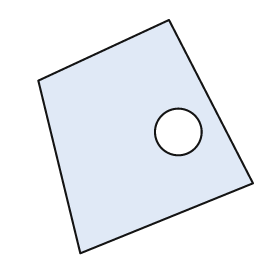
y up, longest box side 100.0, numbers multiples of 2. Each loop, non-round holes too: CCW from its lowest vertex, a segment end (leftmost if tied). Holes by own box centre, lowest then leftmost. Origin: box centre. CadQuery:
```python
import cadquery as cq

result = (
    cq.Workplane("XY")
    .moveTo(-28.0, -50.0)
    .lineTo(46.0, -20.0)
    .lineTo(10.0, 50.0)
    .lineTo(-46.0, 24.0)
    .close()
    .moveTo(14.0, 2.0)
    .circle(10.0)
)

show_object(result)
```